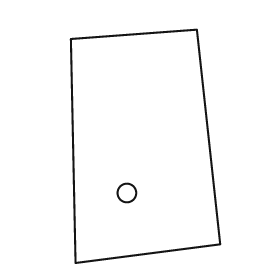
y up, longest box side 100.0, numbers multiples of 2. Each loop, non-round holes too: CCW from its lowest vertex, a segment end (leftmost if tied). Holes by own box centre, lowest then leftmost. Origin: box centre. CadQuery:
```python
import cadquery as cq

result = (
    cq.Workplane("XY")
    .moveTo(-30.0, -50.0)
    .lineTo(32.0, -42.0)
    .lineTo(22.0, 50.0)
    .lineTo(-32.0, 46.0)
    .close()
    .moveTo(-8.0, -20.0)
    .circle(4.0)
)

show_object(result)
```